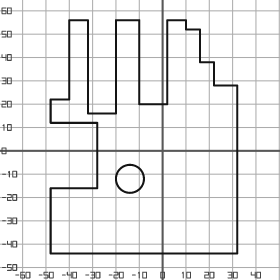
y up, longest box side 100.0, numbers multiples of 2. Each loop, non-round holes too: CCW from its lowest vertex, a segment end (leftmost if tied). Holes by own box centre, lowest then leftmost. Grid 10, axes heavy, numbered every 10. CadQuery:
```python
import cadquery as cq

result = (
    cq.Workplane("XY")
    .moveTo(-48.0, -44.0)
    .lineTo(32.0, -44.0)
    .lineTo(32.0, 28.0)
    .lineTo(22.0, 28.0)
    .lineTo(22.0, 38.0)
    .lineTo(16.0, 38.0)
    .lineTo(16.0, 52.0)
    .lineTo(10.0, 52.0)
    .lineTo(10.0, 56.0)
    .lineTo(2.0, 56.0)
    .lineTo(2.0, 20.0)
    .lineTo(-10.0, 20.0)
    .lineTo(-10.0, 56.0)
    .lineTo(-20.0, 56.0)
    .lineTo(-20.0, 16.0)
    .lineTo(-32.0, 16.0)
    .lineTo(-32.0, 56.0)
    .lineTo(-40.0, 56.0)
    .lineTo(-40.0, 22.0)
    .lineTo(-48.0, 22.0)
    .lineTo(-48.0, 12.0)
    .lineTo(-28.0, 12.0)
    .lineTo(-28.0, -16.0)
    .lineTo(-48.0, -16.0)
    .close()
    .moveTo(-14.0, -12.0)
    .circle(6.0)
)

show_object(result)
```